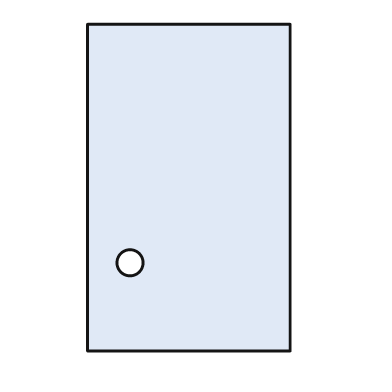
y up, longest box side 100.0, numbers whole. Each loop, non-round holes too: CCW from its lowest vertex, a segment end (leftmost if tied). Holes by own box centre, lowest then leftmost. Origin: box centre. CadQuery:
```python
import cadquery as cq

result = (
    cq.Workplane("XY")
    .moveTo(-31.0, -50.0)
    .lineTo(31.0, -50.0)
    .lineTo(31.0, 50.0)
    .lineTo(-31.0, 50.0)
    .close()
    .moveTo(-18.0, -23.0)
    .circle(4.0)
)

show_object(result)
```